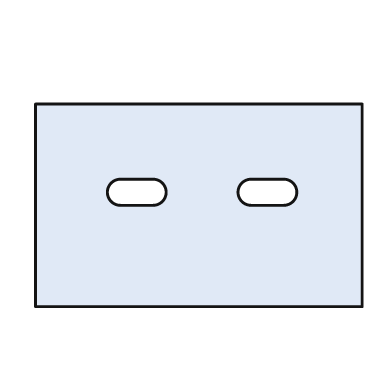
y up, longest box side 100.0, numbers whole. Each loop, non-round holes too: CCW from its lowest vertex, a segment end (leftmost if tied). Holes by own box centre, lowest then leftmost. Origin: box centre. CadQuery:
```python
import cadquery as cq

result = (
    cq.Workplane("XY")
    .moveTo(-50.0, -31.0)
    .lineTo(50.0, -31.0)
    .lineTo(50.0, 31.0)
    .lineTo(-50.0, 31.0)
    .close()
    .moveTo(-24.0, 0.0)
    .lineTo(-14.0, 0.0)
    .threePointArc((-10.0, 4.0), (-14.0, 8.0))
    .lineTo(-24.0, 8.0)
    .threePointArc((-28.0, 4.0), (-24.0, 0.0))
    .close()
    .moveTo(16.0, 0.0)
    .lineTo(26.0, 0.0)
    .threePointArc((30.0, 4.0), (26.0, 8.0))
    .lineTo(16.0, 8.0)
    .threePointArc((12.0, 4.0), (16.0, 0.0))
    .close()
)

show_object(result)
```